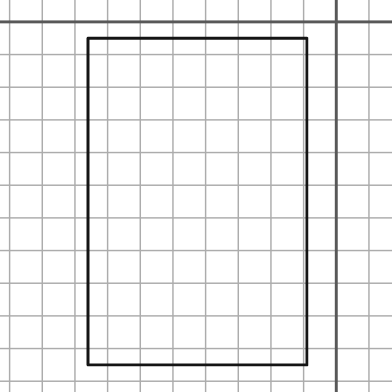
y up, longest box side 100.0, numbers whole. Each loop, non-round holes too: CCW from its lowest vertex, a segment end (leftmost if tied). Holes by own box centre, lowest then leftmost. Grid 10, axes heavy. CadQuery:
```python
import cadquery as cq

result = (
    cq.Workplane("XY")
    .moveTo(-76.0, -105.0)
    .lineTo(-9.0, -105.0)
    .lineTo(-9.0, -5.0)
    .lineTo(-76.0, -5.0)
    .close()
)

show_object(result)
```